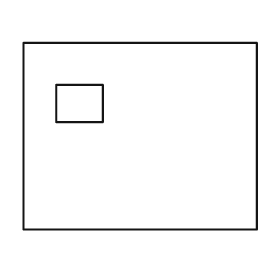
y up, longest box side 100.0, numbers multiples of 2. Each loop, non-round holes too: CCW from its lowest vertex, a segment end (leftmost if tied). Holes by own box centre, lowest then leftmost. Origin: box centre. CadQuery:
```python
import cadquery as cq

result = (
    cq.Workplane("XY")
    .moveTo(-50.0, -40.0)
    .lineTo(50.0, -40.0)
    .lineTo(50.0, 40.0)
    .lineTo(-50.0, 40.0)
    .close()
    .moveTo(-36.0, 6.0)
    .lineTo(-16.0, 6.0)
    .lineTo(-16.0, 22.0)
    .lineTo(-36.0, 22.0)
    .close()
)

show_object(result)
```